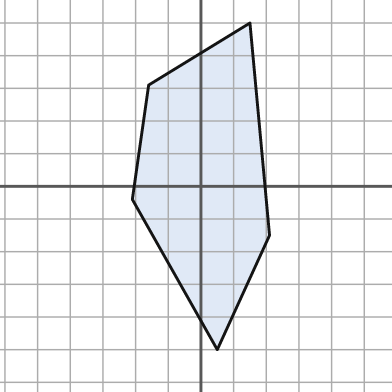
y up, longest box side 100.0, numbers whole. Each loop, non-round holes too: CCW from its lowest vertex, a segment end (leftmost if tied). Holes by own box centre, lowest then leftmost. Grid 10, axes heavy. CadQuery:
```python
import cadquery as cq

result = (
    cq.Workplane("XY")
    .moveTo(5.0, -50.0)
    .lineTo(21.0, -15.0)
    .lineTo(15.0, 50.0)
    .lineTo(-16.0, 31.0)
    .lineTo(-21.0, -4.0)
    .close()
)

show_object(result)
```